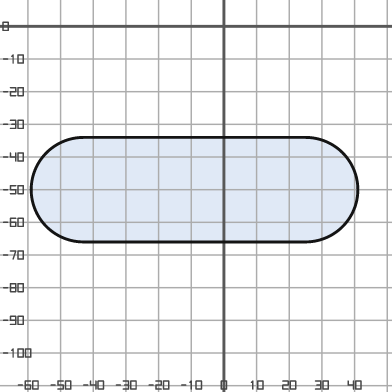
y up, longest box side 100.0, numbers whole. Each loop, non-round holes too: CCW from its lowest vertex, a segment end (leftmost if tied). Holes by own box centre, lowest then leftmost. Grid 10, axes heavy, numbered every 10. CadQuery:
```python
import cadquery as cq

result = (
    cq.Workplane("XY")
    .moveTo(-43.0, -66.0)
    .lineTo(25.0, -66.0)
    .threePointArc((41.0, -50.0), (25.0, -34.0))
    .lineTo(-43.0, -34.0)
    .threePointArc((-59.0, -50.0), (-43.0, -66.0))
    .close()
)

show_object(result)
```